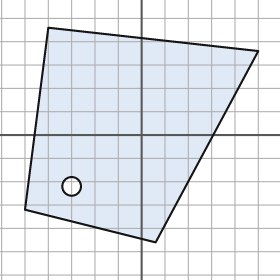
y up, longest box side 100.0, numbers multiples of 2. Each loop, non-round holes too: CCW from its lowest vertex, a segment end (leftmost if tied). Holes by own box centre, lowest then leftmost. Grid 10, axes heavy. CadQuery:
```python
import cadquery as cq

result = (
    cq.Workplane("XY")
    .moveTo(6.0, -46.0)
    .lineTo(50.0, 36.0)
    .lineTo(-40.0, 46.0)
    .lineTo(-50.0, -32.0)
    .close()
    .moveTo(-30.0, -22.0)
    .circle(4.0)
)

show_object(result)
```